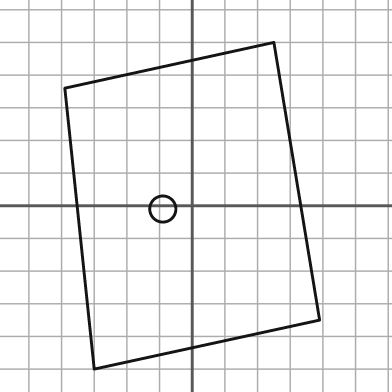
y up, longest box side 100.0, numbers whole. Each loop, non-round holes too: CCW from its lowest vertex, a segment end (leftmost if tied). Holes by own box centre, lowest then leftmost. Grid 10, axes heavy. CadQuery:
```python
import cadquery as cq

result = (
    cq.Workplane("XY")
    .moveTo(-30.0, -50.0)
    .lineTo(39.0, -35.0)
    .lineTo(25.0, 50.0)
    .lineTo(-39.0, 36.0)
    .close()
    .moveTo(-9.0, -1.0)
    .circle(4.0)
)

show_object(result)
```